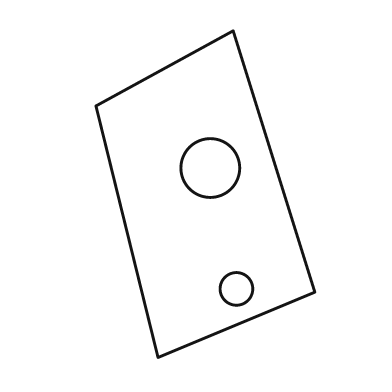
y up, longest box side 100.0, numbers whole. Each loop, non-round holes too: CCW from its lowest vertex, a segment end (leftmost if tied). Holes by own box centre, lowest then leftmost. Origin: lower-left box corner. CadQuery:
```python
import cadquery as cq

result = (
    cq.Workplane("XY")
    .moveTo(19.0, 0.0)
    .lineTo(67.0, 20.0)
    .lineTo(42.0, 100.0)
    .lineTo(0.0, 77.0)
    .close()
    .moveTo(43.0, 21.0)
    .circle(5.0)
    .moveTo(35.0, 58.0)
    .circle(9.0)
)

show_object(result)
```